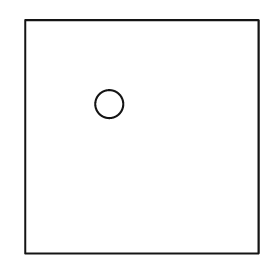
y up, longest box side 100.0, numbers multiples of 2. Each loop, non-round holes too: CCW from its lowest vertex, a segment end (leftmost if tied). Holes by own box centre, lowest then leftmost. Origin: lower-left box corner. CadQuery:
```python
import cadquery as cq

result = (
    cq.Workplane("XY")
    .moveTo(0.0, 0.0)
    .lineTo(100.0, 0.0)
    .lineTo(100.0, 100.0)
    .lineTo(0.0, 100.0)
    .close()
    .moveTo(36.0, 64.0)
    .circle(6.0)
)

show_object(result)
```